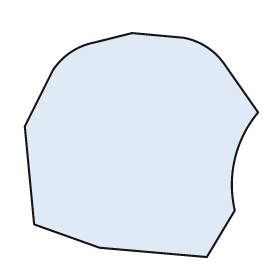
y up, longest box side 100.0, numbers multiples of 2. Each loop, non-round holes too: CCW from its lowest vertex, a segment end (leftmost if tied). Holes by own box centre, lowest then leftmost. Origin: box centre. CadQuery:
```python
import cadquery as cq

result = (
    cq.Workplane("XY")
    .moveTo(28.0, -48.0)
    .lineTo(40.0, -28.0)
    .threePointArc((40.0, -6.0), (50.0, 14.0))
    .lineTo(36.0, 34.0)
    .threePointArc((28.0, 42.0), (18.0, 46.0))
    .lineTo(-4.0, 48.0)
    .lineTo(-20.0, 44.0)
    .threePointArc((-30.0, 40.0), (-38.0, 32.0))
    .lineTo(-50.0, 8.0)
    .lineTo(-46.0, -34.0)
    .lineTo(-18.0, -44.0)
    .close()
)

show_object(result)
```